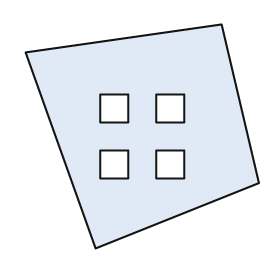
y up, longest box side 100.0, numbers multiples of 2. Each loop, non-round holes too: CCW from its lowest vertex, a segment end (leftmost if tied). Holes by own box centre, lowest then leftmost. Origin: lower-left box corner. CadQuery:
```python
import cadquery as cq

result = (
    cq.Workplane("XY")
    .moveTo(30.0, 0.0)
    .lineTo(100.0, 28.0)
    .lineTo(84.0, 96.0)
    .lineTo(0.0, 84.0)
    .close()
    .moveTo(32.0, 30.0)
    .lineTo(44.0, 30.0)
    .lineTo(44.0, 42.0)
    .lineTo(32.0, 42.0)
    .close()
    .moveTo(56.0, 30.0)
    .lineTo(68.0, 30.0)
    .lineTo(68.0, 42.0)
    .lineTo(56.0, 42.0)
    .close()
    .moveTo(32.0, 54.0)
    .lineTo(44.0, 54.0)
    .lineTo(44.0, 66.0)
    .lineTo(32.0, 66.0)
    .close()
    .moveTo(56.0, 54.0)
    .lineTo(68.0, 54.0)
    .lineTo(68.0, 66.0)
    .lineTo(56.0, 66.0)
    .close()
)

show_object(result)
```